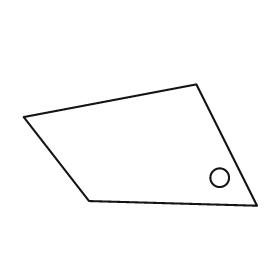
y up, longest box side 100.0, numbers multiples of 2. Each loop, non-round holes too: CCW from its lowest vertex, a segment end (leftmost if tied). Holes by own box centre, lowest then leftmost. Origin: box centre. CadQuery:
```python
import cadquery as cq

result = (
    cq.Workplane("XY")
    .moveTo(50.0, -26.0)
    .lineTo(24.0, 26.0)
    .lineTo(-50.0, 12.0)
    .lineTo(-22.0, -24.0)
    .close()
    .moveTo(34.0, -14.0)
    .circle(4.0)
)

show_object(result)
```